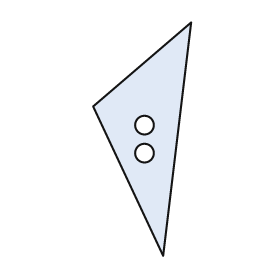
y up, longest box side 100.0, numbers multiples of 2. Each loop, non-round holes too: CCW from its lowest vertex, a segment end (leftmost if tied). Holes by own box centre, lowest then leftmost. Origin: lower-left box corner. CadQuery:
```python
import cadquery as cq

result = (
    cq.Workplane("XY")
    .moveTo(30.0, 0.0)
    .lineTo(42.0, 100.0)
    .lineTo(0.0, 64.0)
    .close()
    .moveTo(22.0, 44.0)
    .circle(4.0)
    .moveTo(22.0, 56.0)
    .circle(4.0)
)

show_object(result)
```